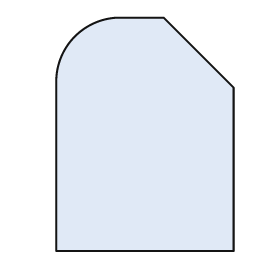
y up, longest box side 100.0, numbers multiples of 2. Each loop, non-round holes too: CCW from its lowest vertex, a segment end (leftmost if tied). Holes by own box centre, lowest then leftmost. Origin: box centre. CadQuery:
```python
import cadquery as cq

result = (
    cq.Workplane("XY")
    .moveTo(-38.0, -50.0)
    .lineTo(38.0, -50.0)
    .lineTo(38.0, 20.0)
    .lineTo(8.0, 50.0)
    .lineTo(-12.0, 50.0)
    .threePointArc((-30.0, 42.0), (-38.0, 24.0))
    .close()
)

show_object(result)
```